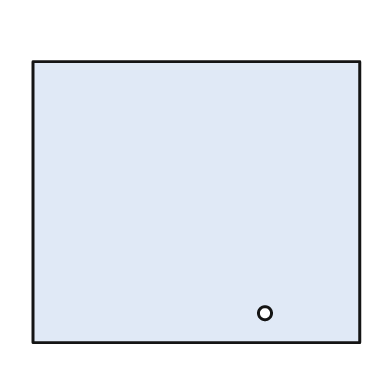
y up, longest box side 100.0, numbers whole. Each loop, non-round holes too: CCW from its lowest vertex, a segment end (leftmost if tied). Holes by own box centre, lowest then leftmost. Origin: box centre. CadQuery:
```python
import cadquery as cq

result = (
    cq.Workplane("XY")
    .moveTo(-50.0, -43.0)
    .lineTo(50.0, -43.0)
    .lineTo(50.0, 43.0)
    .lineTo(-50.0, 43.0)
    .close()
    .moveTo(21.0, -34.0)
    .circle(2.0)
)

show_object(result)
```